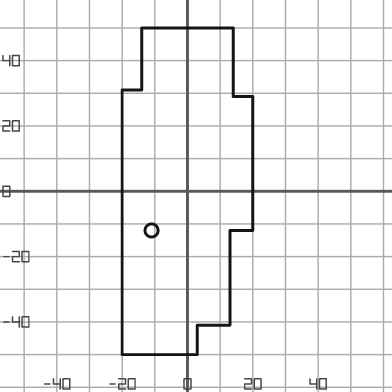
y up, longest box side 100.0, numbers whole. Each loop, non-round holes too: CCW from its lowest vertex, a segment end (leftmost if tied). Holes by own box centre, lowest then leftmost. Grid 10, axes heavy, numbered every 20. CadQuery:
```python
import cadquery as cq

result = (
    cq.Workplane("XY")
    .moveTo(-20.0, -50.0)
    .lineTo(3.0, -50.0)
    .lineTo(3.0, -41.0)
    .lineTo(13.0, -41.0)
    .lineTo(13.0, -12.0)
    .lineTo(20.0, -12.0)
    .lineTo(20.0, 29.0)
    .lineTo(14.0, 29.0)
    .lineTo(14.0, 50.0)
    .lineTo(-14.0, 50.0)
    .lineTo(-14.0, 31.0)
    .lineTo(-20.0, 31.0)
    .close()
    .moveTo(-11.0, -12.0)
    .circle(2.0)
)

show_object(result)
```